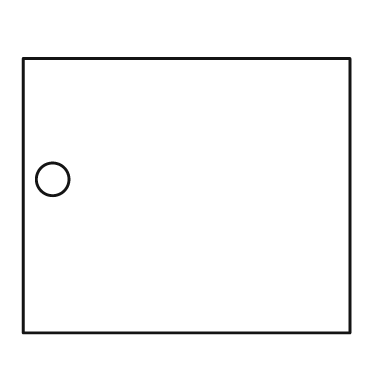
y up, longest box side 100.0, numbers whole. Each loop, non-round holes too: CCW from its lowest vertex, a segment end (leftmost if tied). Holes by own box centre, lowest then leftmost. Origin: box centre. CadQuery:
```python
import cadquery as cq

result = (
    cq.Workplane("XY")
    .moveTo(-50.0, -42.0)
    .lineTo(50.0, -42.0)
    .lineTo(50.0, 42.0)
    .lineTo(-50.0, 42.0)
    .close()
    .moveTo(-41.0, 5.0)
    .circle(5.0)
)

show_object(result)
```